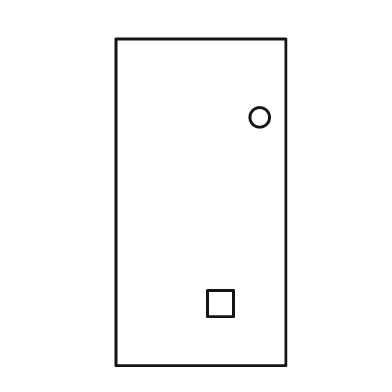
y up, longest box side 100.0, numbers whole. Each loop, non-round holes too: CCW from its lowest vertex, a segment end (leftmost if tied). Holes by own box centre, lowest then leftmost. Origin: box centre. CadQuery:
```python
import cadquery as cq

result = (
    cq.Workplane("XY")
    .moveTo(-26.0, -50.0)
    .lineTo(26.0, -50.0)
    .lineTo(26.0, 50.0)
    .lineTo(-26.0, 50.0)
    .close()
    .moveTo(2.0, -35.0)
    .lineTo(10.0, -35.0)
    .lineTo(10.0, -27.0)
    .lineTo(2.0, -27.0)
    .close()
    .moveTo(18.0, 26.0)
    .circle(3.0)
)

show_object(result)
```